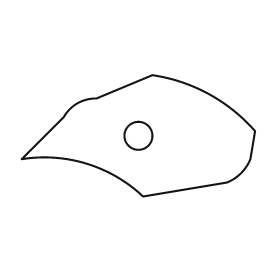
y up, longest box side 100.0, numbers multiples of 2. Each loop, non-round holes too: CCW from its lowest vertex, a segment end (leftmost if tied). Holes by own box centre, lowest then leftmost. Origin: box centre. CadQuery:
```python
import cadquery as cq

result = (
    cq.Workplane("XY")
    .moveTo(2.0, -26.0)
    .lineTo(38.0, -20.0)
    .threePointArc((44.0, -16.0), (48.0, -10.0))
    .lineTo(50.0, 2.0)
    .threePointArc((30.0, 18.0), (6.0, 26.0))
    .lineTo(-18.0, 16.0)
    .threePointArc((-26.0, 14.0), (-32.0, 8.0))
    .lineTo(-50.0, -10.0)
    .threePointArc((-22.0, -12.0), (2.0, -26.0))
    .close()
    .moveTo(0.0, 0.0)
    .circle(6.0)
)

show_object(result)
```